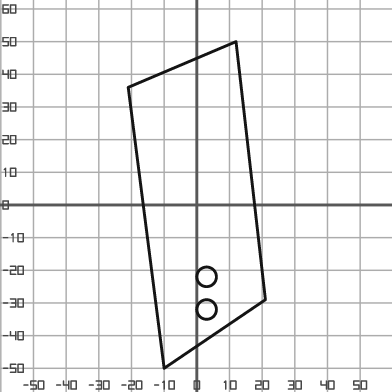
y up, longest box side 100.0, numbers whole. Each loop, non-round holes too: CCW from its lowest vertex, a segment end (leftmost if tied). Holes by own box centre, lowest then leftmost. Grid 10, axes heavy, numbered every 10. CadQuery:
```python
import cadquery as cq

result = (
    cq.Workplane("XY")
    .moveTo(-10.0, -50.0)
    .lineTo(21.0, -29.0)
    .lineTo(12.0, 50.0)
    .lineTo(-21.0, 36.0)
    .close()
    .moveTo(3.0, -32.0)
    .circle(3.0)
    .moveTo(3.0, -22.0)
    .circle(3.0)
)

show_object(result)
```